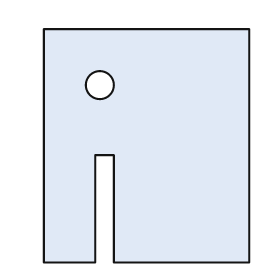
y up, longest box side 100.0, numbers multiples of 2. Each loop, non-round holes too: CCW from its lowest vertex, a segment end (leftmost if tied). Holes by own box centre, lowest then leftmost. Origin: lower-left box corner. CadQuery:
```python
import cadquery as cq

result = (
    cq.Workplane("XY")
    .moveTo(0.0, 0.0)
    .lineTo(22.0, 0.0)
    .lineTo(22.0, 46.0)
    .lineTo(30.0, 46.0)
    .lineTo(30.0, 0.0)
    .lineTo(88.0, 0.0)
    .lineTo(88.0, 100.0)
    .lineTo(0.0, 100.0)
    .close()
    .moveTo(24.0, 76.0)
    .circle(6.0)
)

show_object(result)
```